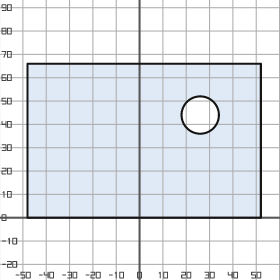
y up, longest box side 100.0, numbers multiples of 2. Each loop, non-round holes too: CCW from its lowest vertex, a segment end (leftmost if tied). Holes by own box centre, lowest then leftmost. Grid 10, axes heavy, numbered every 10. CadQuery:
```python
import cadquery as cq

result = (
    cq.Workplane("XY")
    .moveTo(-48.0, 0.0)
    .lineTo(52.0, 0.0)
    .lineTo(52.0, 66.0)
    .lineTo(-48.0, 66.0)
    .close()
    .moveTo(26.0, 44.0)
    .circle(8.0)
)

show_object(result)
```